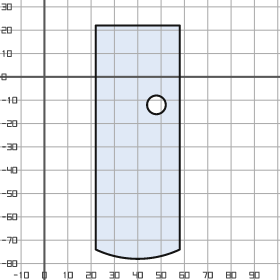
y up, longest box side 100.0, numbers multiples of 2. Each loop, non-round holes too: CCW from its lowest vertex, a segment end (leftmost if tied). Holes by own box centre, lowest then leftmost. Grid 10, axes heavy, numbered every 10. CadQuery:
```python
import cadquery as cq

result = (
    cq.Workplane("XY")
    .moveTo(22.0, -74.0)
    .threePointArc((40.0, -78.0), (58.0, -74.0))
    .lineTo(58.0, 22.0)
    .lineTo(22.0, 22.0)
    .close()
    .moveTo(48.0, -12.0)
    .circle(4.0)
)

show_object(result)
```